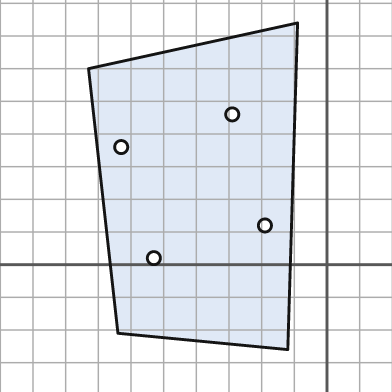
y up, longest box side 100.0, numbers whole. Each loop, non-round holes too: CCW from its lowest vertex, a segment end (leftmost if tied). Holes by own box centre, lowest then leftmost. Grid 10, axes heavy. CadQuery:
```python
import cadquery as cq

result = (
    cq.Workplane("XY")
    .moveTo(-12.0, -26.0)
    .lineTo(-9.0, 74.0)
    .lineTo(-73.0, 60.0)
    .lineTo(-64.0, -21.0)
    .close()
    .moveTo(-53.0, 2.0)
    .circle(2.0)
    .moveTo(-19.0, 12.0)
    .circle(2.0)
    .moveTo(-63.0, 36.0)
    .circle(2.0)
    .moveTo(-29.0, 46.0)
    .circle(2.0)
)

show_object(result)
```